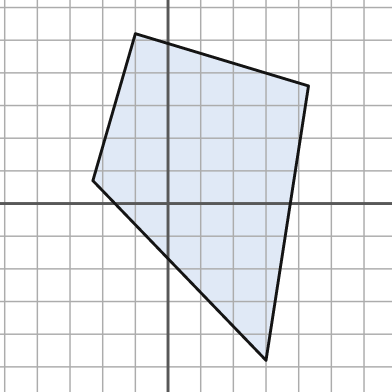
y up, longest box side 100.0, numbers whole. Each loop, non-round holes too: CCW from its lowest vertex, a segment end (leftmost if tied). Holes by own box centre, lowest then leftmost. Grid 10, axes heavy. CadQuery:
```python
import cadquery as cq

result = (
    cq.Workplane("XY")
    .moveTo(30.0, -48.0)
    .lineTo(43.0, 36.0)
    .lineTo(-10.0, 52.0)
    .lineTo(-23.0, 7.0)
    .close()
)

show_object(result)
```